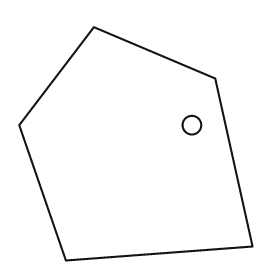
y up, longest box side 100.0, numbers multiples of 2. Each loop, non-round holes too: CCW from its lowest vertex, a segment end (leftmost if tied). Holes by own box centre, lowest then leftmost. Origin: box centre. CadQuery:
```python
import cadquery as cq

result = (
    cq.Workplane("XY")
    .moveTo(-30.0, -50.0)
    .lineTo(50.0, -44.0)
    .lineTo(34.0, 28.0)
    .lineTo(-18.0, 50.0)
    .lineTo(-50.0, 8.0)
    .close()
    .moveTo(24.0, 8.0)
    .circle(4.0)
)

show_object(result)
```